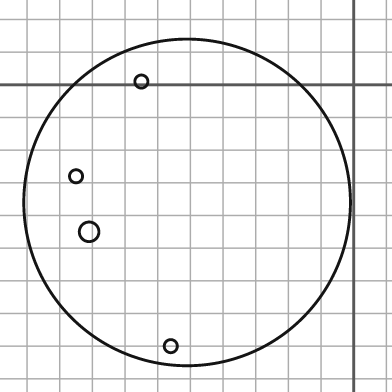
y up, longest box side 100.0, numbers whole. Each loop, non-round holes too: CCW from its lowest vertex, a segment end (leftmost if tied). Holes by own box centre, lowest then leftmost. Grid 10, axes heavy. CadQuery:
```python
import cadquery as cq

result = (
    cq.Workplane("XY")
    .moveTo(-51.0, -36.0)
    .circle(50.0)
    .moveTo(-56.0, -80.0)
    .circle(2.0)
    .moveTo(-81.0, -45.0)
    .circle(3.0)
    .moveTo(-85.0, -28.0)
    .circle(2.0)
    .moveTo(-65.0, 1.0)
    .circle(2.0)
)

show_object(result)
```